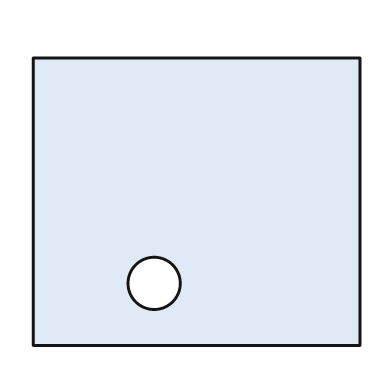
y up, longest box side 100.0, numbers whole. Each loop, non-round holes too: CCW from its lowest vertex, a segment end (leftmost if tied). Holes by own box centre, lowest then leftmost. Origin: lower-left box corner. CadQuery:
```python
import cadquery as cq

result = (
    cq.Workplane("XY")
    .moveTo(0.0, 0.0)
    .lineTo(100.0, 0.0)
    .lineTo(100.0, 88.0)
    .lineTo(0.0, 88.0)
    .close()
    .moveTo(37.0, 19.0)
    .circle(8.0)
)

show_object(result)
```